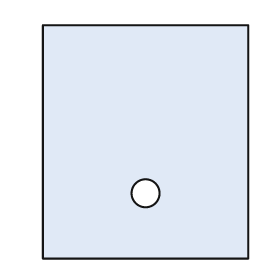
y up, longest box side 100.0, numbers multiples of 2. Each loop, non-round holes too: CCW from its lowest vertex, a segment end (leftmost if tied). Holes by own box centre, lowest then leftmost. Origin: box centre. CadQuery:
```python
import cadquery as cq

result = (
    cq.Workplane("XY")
    .moveTo(-44.0, -50.0)
    .lineTo(44.0, -50.0)
    .lineTo(44.0, 50.0)
    .lineTo(-44.0, 50.0)
    .close()
    .moveTo(0.0, -22.0)
    .circle(6.0)
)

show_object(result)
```